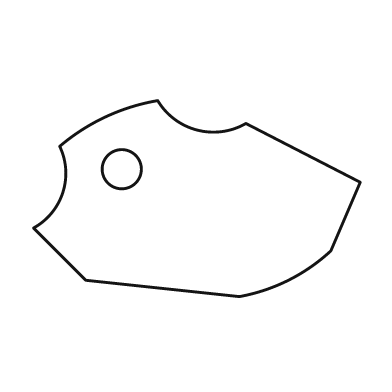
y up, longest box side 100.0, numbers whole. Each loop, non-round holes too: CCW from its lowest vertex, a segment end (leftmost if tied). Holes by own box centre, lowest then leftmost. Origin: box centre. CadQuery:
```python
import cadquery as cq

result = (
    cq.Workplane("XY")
    .moveTo(13.0, -30.0)
    .threePointArc((28.0, -25.0), (41.0, -16.0))
    .lineTo(50.0, 5.0)
    .lineTo(15.0, 23.0)
    .threePointArc((0.0, 21.0), (-12.0, 30.0))
    .threePointArc((-28.0, 25.0), (-42.0, 16.0))
    .threePointArc((-41.0, 2.0), (-50.0, -9.0))
    .lineTo(-34.0, -25.0)
    .close()
    .moveTo(-23.0, 9.0)
    .circle(6.0)
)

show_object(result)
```